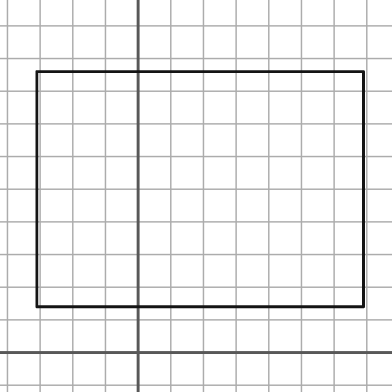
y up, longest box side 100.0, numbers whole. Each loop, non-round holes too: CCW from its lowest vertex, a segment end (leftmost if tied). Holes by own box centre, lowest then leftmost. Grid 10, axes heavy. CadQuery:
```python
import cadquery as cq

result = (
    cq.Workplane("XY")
    .moveTo(-31.0, 14.0)
    .lineTo(69.0, 14.0)
    .lineTo(69.0, 86.0)
    .lineTo(-31.0, 86.0)
    .close()
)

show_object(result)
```